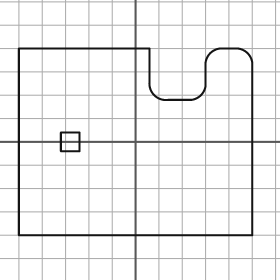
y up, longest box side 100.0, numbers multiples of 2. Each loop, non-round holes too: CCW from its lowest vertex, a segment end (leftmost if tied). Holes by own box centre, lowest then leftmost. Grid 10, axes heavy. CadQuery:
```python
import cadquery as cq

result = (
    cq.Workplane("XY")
    .moveTo(-50.0, -40.0)
    .lineTo(50.0, -40.0)
    .lineTo(50.0, 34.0)
    .threePointArc((48.0, 38.0), (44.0, 40.0))
    .lineTo(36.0, 40.0)
    .threePointArc((32.0, 38.0), (30.0, 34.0))
    .lineTo(30.0, 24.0)
    .threePointArc((28.0, 20.0), (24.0, 18.0))
    .lineTo(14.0, 18.0)
    .threePointArc((8.0, 20.0), (6.0, 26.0))
    .lineTo(6.0, 40.0)
    .lineTo(-50.0, 40.0)
    .close()
    .moveTo(-32.0, -4.0)
    .lineTo(-24.0, -4.0)
    .lineTo(-24.0, 4.0)
    .lineTo(-32.0, 4.0)
    .close()
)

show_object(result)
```